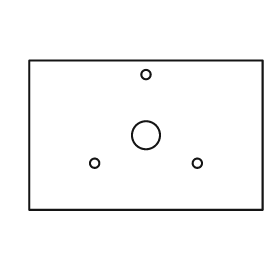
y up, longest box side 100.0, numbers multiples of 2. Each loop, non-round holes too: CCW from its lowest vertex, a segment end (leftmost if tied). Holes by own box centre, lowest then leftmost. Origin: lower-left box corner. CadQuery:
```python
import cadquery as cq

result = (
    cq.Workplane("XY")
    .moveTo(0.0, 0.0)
    .lineTo(100.0, 0.0)
    .lineTo(100.0, 64.0)
    .lineTo(0.0, 64.0)
    .close()
    .moveTo(28.0, 20.0)
    .circle(2.0)
    .moveTo(72.0, 20.0)
    .circle(2.0)
    .moveTo(50.0, 32.0)
    .circle(6.0)
    .moveTo(50.0, 58.0)
    .circle(2.0)
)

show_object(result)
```